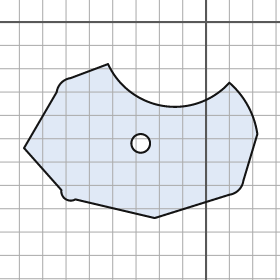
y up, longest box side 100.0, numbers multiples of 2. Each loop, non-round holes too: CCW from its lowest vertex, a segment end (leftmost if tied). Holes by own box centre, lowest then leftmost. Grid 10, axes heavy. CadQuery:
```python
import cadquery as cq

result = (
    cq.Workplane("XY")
    .moveTo(-22.0, -84.0)
    .lineTo(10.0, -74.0)
    .threePointArc((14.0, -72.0), (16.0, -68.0))
    .lineTo(22.0, -48.0)
    .threePointArc((18.0, -36.0), (10.0, -26.0))
    .threePointArc((-18.0, -36.0), (-42.0, -18.0))
    .lineTo(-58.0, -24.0)
    .threePointArc((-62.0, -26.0), (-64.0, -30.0))
    .lineTo(-78.0, -54.0)
    .lineTo(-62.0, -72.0)
    .threePointArc((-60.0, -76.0), (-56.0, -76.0))
    .close()
    .moveTo(-28.0, -52.0)
    .circle(4.0)
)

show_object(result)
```